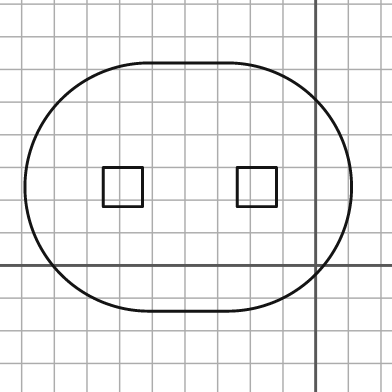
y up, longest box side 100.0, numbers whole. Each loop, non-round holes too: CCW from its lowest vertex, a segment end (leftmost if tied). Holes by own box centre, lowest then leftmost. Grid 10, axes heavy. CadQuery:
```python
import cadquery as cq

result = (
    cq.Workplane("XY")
    .moveTo(-51.0, -14.0)
    .lineTo(-27.0, -14.0)
    .threePointArc((11.0, 24.0), (-27.0, 62.0))
    .lineTo(-51.0, 62.0)
    .threePointArc((-89.0, 24.0), (-51.0, -14.0))
    .close()
    .moveTo(-65.0, 18.0)
    .lineTo(-53.0, 18.0)
    .lineTo(-53.0, 30.0)
    .lineTo(-65.0, 30.0)
    .close()
    .moveTo(-24.0, 18.0)
    .lineTo(-12.0, 18.0)
    .lineTo(-12.0, 30.0)
    .lineTo(-24.0, 30.0)
    .close()
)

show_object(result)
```